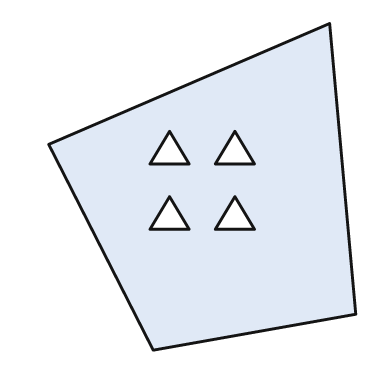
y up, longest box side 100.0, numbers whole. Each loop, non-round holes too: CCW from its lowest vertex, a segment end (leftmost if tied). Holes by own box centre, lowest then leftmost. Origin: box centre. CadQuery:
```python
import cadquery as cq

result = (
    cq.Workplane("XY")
    .moveTo(-15.0, -50.0)
    .lineTo(47.0, -39.0)
    .lineTo(39.0, 50.0)
    .lineTo(-47.0, 13.0)
    .close()
    .moveTo(-16.0, -13.0)
    .lineTo(-4.0, -13.0)
    .lineTo(-10.0, -3.0)
    .close()
    .moveTo(4.0, -13.0)
    .lineTo(16.0, -13.0)
    .lineTo(10.0, -3.0)
    .close()
    .moveTo(-16.0, 7.0)
    .lineTo(-4.0, 7.0)
    .lineTo(-10.0, 17.0)
    .close()
    .moveTo(4.0, 7.0)
    .lineTo(16.0, 7.0)
    .lineTo(10.0, 17.0)
    .close()
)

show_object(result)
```